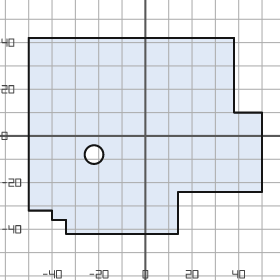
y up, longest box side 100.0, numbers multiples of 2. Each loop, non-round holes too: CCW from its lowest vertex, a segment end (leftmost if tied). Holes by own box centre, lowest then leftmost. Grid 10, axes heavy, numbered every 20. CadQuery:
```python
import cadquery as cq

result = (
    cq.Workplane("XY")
    .moveTo(-34.0, -42.0)
    .lineTo(14.0, -42.0)
    .lineTo(14.0, -24.0)
    .lineTo(50.0, -24.0)
    .lineTo(50.0, 10.0)
    .lineTo(38.0, 10.0)
    .lineTo(38.0, 42.0)
    .lineTo(-50.0, 42.0)
    .lineTo(-50.0, -32.0)
    .lineTo(-40.0, -32.0)
    .lineTo(-40.0, -36.0)
    .lineTo(-34.0, -36.0)
    .close()
    .moveTo(-22.0, -8.0)
    .circle(4.0)
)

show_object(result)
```